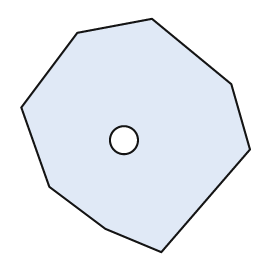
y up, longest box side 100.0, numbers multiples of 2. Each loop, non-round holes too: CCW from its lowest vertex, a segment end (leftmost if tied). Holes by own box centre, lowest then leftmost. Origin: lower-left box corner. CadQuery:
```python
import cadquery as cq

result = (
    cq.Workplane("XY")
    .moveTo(60.0, 0.0)
    .lineTo(98.0, 44.0)
    .lineTo(90.0, 72.0)
    .lineTo(56.0, 100.0)
    .lineTo(24.0, 94.0)
    .lineTo(0.0, 62.0)
    .lineTo(12.0, 28.0)
    .lineTo(36.0, 10.0)
    .close()
    .moveTo(44.0, 48.0)
    .circle(6.0)
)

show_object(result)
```